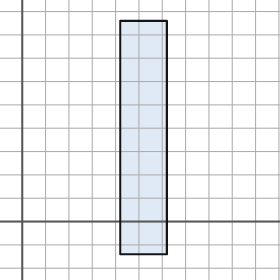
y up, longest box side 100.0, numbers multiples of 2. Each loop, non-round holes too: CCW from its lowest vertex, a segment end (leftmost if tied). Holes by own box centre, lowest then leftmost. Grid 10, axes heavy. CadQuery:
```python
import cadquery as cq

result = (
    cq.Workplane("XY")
    .moveTo(42.0, -14.0)
    .lineTo(62.0, -14.0)
    .lineTo(62.0, 86.0)
    .lineTo(42.0, 86.0)
    .close()
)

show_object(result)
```